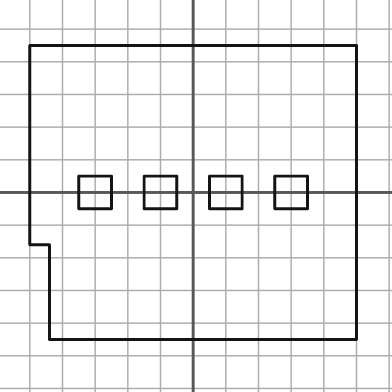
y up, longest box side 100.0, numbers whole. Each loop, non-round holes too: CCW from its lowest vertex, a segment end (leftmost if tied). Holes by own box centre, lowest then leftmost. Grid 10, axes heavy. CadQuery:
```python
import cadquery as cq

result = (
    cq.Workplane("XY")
    .moveTo(-44.0, -45.0)
    .lineTo(50.0, -45.0)
    .lineTo(50.0, 45.0)
    .lineTo(-50.0, 45.0)
    .lineTo(-50.0, -16.0)
    .lineTo(-44.0, -16.0)
    .close()
    .moveTo(-35.0, -5.0)
    .lineTo(-25.0, -5.0)
    .lineTo(-25.0, 5.0)
    .lineTo(-35.0, 5.0)
    .close()
    .moveTo(-15.0, -5.0)
    .lineTo(-5.0, -5.0)
    .lineTo(-5.0, 5.0)
    .lineTo(-15.0, 5.0)
    .close()
    .moveTo(5.0, -5.0)
    .lineTo(15.0, -5.0)
    .lineTo(15.0, 5.0)
    .lineTo(5.0, 5.0)
    .close()
    .moveTo(25.0, -5.0)
    .lineTo(35.0, -5.0)
    .lineTo(35.0, 5.0)
    .lineTo(25.0, 5.0)
    .close()
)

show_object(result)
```